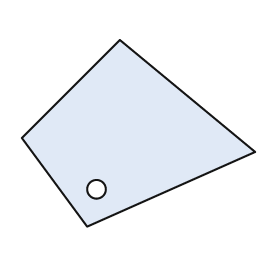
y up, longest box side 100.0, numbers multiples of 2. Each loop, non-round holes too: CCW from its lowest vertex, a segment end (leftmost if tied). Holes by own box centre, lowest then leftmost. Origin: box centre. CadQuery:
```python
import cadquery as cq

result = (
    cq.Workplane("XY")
    .moveTo(-22.0, -40.0)
    .lineTo(50.0, -8.0)
    .lineTo(-8.0, 40.0)
    .lineTo(-50.0, -2.0)
    .close()
    .moveTo(-18.0, -24.0)
    .circle(4.0)
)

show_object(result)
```